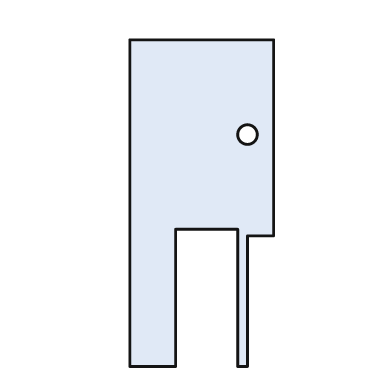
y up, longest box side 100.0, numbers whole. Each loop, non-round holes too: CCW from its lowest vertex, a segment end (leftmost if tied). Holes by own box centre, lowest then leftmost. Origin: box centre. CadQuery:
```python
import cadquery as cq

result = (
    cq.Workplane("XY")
    .moveTo(-22.0, -50.0)
    .lineTo(-8.0, -50.0)
    .lineTo(-8.0, -8.0)
    .lineTo(11.0, -8.0)
    .lineTo(11.0, -50.0)
    .lineTo(14.0, -50.0)
    .lineTo(14.0, -10.0)
    .lineTo(22.0, -10.0)
    .lineTo(22.0, 50.0)
    .lineTo(-22.0, 50.0)
    .close()
    .moveTo(14.0, 21.0)
    .circle(3.0)
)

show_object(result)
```